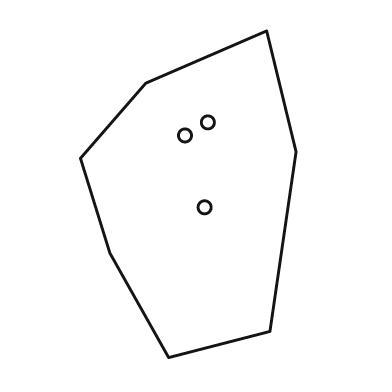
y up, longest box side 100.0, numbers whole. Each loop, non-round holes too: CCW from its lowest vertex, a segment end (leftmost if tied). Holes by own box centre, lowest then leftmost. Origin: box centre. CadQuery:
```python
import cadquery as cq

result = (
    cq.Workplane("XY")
    .moveTo(-6.0, -50.0)
    .lineTo(25.0, -42.0)
    .lineTo(33.0, 13.0)
    .lineTo(24.0, 50.0)
    .lineTo(-13.0, 34.0)
    .lineTo(-33.0, 11.0)
    .lineTo(-24.0, -18.0)
    .close()
    .moveTo(5.0, -4.0)
    .circle(2.0)
    .moveTo(-1.0, 18.0)
    .circle(2.0)
    .moveTo(6.0, 22.0)
    .circle(2.0)
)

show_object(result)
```